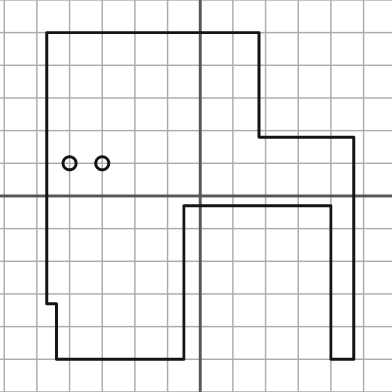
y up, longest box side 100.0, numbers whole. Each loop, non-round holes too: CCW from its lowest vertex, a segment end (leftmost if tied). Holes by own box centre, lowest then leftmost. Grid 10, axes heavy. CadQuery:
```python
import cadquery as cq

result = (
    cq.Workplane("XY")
    .moveTo(-44.0, -50.0)
    .lineTo(-5.0, -50.0)
    .lineTo(-5.0, -3.0)
    .lineTo(40.0, -3.0)
    .lineTo(40.0, -50.0)
    .lineTo(47.0, -50.0)
    .lineTo(47.0, 18.0)
    .lineTo(18.0, 18.0)
    .lineTo(18.0, 50.0)
    .lineTo(-47.0, 50.0)
    .lineTo(-47.0, -33.0)
    .lineTo(-44.0, -33.0)
    .close()
    .moveTo(-40.0, 10.0)
    .circle(2.0)
    .moveTo(-30.0, 10.0)
    .circle(2.0)
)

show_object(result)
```